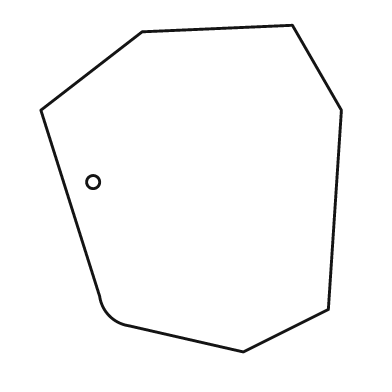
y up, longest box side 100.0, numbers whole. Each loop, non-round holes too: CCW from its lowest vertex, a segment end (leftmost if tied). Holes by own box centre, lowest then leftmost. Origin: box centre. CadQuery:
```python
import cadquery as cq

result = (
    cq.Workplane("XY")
    .moveTo(16.0, -50.0)
    .lineTo(42.0, -37.0)
    .lineTo(46.0, 24.0)
    .lineTo(31.0, 50.0)
    .lineTo(-15.0, 48.0)
    .lineTo(-46.0, 24.0)
    .lineTo(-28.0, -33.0)
    .threePointArc((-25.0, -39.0), (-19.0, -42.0))
    .close()
    .moveTo(-30.0, 2.0)
    .circle(2.0)
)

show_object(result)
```